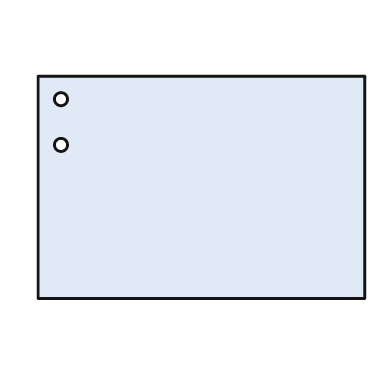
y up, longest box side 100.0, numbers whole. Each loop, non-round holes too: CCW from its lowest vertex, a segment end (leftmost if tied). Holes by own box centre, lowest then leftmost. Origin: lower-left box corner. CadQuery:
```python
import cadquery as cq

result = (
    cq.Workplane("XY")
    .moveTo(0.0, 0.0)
    .lineTo(100.0, 0.0)
    .lineTo(100.0, 68.0)
    .lineTo(0.0, 68.0)
    .close()
    .moveTo(7.0, 47.0)
    .circle(2.0)
    .moveTo(7.0, 61.0)
    .circle(2.0)
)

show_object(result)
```